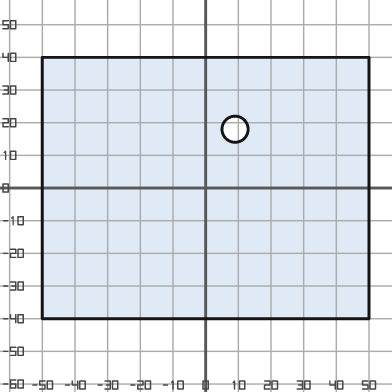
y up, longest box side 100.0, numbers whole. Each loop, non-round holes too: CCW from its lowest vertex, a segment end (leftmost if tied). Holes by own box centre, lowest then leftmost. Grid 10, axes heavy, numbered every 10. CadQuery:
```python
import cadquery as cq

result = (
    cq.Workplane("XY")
    .moveTo(-50.0, -40.0)
    .lineTo(50.0, -40.0)
    .lineTo(50.0, 40.0)
    .lineTo(-50.0, 40.0)
    .close()
    .moveTo(9.0, 18.0)
    .circle(4.0)
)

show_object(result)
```